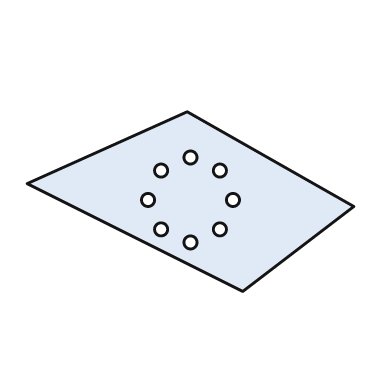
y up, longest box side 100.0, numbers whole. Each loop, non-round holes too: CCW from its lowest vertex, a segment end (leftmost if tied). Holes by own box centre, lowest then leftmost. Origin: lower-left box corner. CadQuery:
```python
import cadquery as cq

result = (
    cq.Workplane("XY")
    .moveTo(66.0, 0.0)
    .lineTo(100.0, 26.0)
    .lineTo(49.0, 55.0)
    .lineTo(0.0, 33.0)
    .close()
    .moveTo(50.0, 15.0)
    .circle(2.0)
    .moveTo(41.0, 19.0)
    .circle(2.0)
    .moveTo(59.0, 19.0)
    .circle(2.0)
    .moveTo(37.0, 28.0)
    .circle(2.0)
    .moveTo(63.0, 28.0)
    .circle(2.0)
    .moveTo(41.0, 37.0)
    .circle(2.0)
    .moveTo(59.0, 37.0)
    .circle(2.0)
    .moveTo(50.0, 41.0)
    .circle(2.0)
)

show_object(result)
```